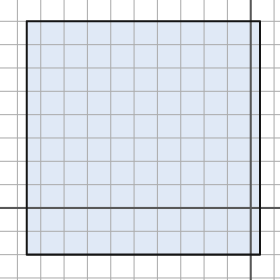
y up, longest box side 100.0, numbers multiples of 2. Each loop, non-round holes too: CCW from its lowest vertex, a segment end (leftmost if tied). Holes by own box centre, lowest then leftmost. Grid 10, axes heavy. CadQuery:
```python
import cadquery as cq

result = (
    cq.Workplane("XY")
    .moveTo(-96.0, -20.0)
    .lineTo(4.0, -20.0)
    .lineTo(4.0, 80.0)
    .lineTo(-96.0, 80.0)
    .close()
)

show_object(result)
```